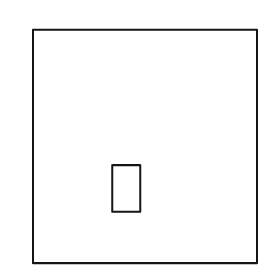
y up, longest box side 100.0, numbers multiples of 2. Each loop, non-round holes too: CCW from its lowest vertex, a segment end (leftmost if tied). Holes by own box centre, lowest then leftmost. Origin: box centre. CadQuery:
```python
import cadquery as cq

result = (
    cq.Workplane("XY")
    .moveTo(-48.0, -50.0)
    .lineTo(48.0, -50.0)
    .lineTo(48.0, 50.0)
    .lineTo(-48.0, 50.0)
    .close()
    .moveTo(-14.0, -28.0)
    .lineTo(-2.0, -28.0)
    .lineTo(-2.0, -8.0)
    .lineTo(-14.0, -8.0)
    .close()
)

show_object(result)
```